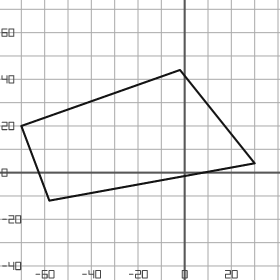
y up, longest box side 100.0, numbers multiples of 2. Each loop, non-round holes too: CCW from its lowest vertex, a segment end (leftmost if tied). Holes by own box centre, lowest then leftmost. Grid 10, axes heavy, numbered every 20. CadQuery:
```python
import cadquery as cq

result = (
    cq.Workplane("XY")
    .moveTo(-58.0, -12.0)
    .lineTo(30.0, 4.0)
    .lineTo(-2.0, 44.0)
    .lineTo(-70.0, 20.0)
    .close()
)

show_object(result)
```